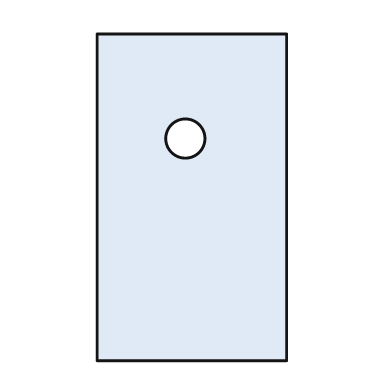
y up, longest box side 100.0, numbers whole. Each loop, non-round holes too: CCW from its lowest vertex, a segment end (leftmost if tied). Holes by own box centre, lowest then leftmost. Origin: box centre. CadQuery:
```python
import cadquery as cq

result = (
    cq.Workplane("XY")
    .moveTo(-29.0, -50.0)
    .lineTo(29.0, -50.0)
    .lineTo(29.0, 50.0)
    .lineTo(-29.0, 50.0)
    .close()
    .moveTo(-2.0, 18.0)
    .circle(6.0)
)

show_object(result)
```